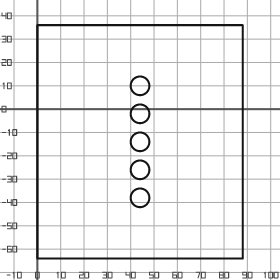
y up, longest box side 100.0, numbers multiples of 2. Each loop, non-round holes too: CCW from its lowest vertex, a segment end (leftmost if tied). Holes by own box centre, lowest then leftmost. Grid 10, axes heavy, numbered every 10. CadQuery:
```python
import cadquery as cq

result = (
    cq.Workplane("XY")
    .moveTo(0.0, -64.0)
    .lineTo(88.0, -64.0)
    .lineTo(88.0, 36.0)
    .lineTo(0.0, 36.0)
    .close()
    .moveTo(44.0, -38.0)
    .circle(4.0)
    .moveTo(44.0, -26.0)
    .circle(4.0)
    .moveTo(44.0, -14.0)
    .circle(4.0)
    .moveTo(44.0, -2.0)
    .circle(4.0)
    .moveTo(44.0, 10.0)
    .circle(4.0)
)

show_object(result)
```